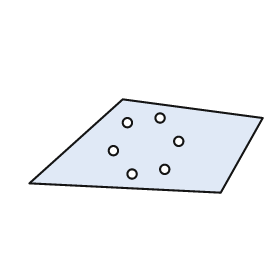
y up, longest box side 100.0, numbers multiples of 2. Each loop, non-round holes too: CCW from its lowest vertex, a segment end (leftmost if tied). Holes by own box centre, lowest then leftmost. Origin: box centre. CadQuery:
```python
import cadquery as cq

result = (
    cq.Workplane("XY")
    .moveTo(32.0, -20.0)
    .lineTo(50.0, 12.0)
    .lineTo(-10.0, 20.0)
    .lineTo(-50.0, -16.0)
    .close()
    .moveTo(-6.0, -12.0)
    .circle(2.0)
    .moveTo(8.0, -10.0)
    .circle(2.0)
    .moveTo(-14.0, -2.0)
    .circle(2.0)
    .moveTo(14.0, 2.0)
    .circle(2.0)
    .moveTo(-8.0, 10.0)
    .circle(2.0)
    .moveTo(6.0, 12.0)
    .circle(2.0)
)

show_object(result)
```